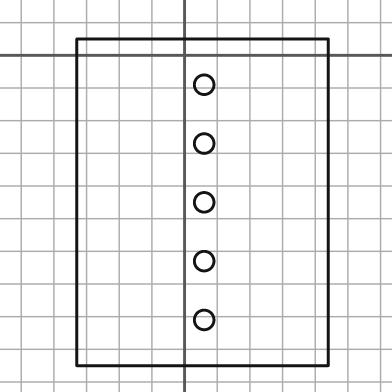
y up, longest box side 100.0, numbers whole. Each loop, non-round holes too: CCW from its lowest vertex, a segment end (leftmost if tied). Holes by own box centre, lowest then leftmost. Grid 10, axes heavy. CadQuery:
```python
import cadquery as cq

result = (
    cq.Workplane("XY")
    .moveTo(-33.0, -95.0)
    .lineTo(44.0, -95.0)
    .lineTo(44.0, 5.0)
    .lineTo(-33.0, 5.0)
    .close()
    .moveTo(6.0, -81.0)
    .circle(3.0)
    .moveTo(6.0, -63.0)
    .circle(3.0)
    .moveTo(6.0, -45.0)
    .circle(3.0)
    .moveTo(6.0, -27.0)
    .circle(3.0)
    .moveTo(6.0, -9.0)
    .circle(3.0)
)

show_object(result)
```